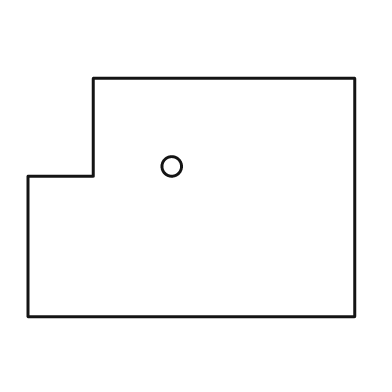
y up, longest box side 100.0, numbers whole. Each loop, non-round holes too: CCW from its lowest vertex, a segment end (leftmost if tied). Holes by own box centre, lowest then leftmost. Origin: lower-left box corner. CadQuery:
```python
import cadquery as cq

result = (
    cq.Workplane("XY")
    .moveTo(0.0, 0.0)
    .lineTo(100.0, 0.0)
    .lineTo(100.0, 73.0)
    .lineTo(20.0, 73.0)
    .lineTo(20.0, 43.0)
    .lineTo(0.0, 43.0)
    .close()
    .moveTo(44.0, 46.0)
    .circle(3.0)
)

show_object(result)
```